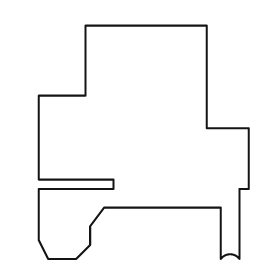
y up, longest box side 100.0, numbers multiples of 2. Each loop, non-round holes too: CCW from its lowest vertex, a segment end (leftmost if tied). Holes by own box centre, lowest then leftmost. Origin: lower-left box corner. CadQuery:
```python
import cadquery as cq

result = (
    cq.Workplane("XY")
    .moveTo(4.0, 0.0)
    .lineTo(16.0, 0.0)
    .lineTo(22.0, 6.0)
    .lineTo(22.0, 14.0)
    .lineTo(28.0, 22.0)
    .lineTo(78.0, 22.0)
    .lineTo(78.0, 0.0)
    .threePointArc((82.0, 2.0), (86.0, 0.0))
    .lineTo(86.0, 30.0)
    .lineTo(90.0, 30.0)
    .lineTo(90.0, 56.0)
    .lineTo(72.0, 56.0)
    .lineTo(72.0, 100.0)
    .lineTo(20.0, 100.0)
    .lineTo(20.0, 70.0)
    .lineTo(0.0, 70.0)
    .lineTo(0.0, 34.0)
    .lineTo(32.0, 34.0)
    .lineTo(32.0, 30.0)
    .lineTo(0.0, 30.0)
    .lineTo(0.0, 8.0)
    .close()
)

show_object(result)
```